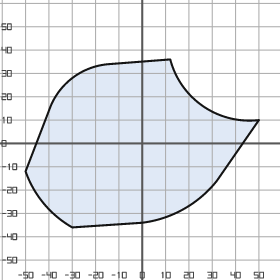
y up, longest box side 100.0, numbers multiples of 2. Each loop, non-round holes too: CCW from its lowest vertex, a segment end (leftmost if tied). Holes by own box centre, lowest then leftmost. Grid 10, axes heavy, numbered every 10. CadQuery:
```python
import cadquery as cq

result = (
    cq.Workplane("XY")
    .moveTo(-30.0, -36.0)
    .lineTo(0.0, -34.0)
    .threePointArc((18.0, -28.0), (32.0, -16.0))
    .lineTo(50.0, 10.0)
    .threePointArc((26.0, 16.0), (12.0, 36.0))
    .lineTo(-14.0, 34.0)
    .threePointArc((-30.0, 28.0), (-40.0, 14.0))
    .lineTo(-50.0, -12.0)
    .threePointArc((-42.0, -26.0), (-30.0, -36.0))
    .close()
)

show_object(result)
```